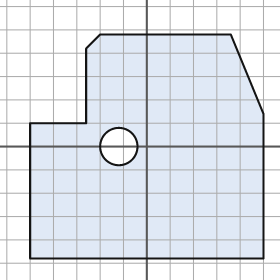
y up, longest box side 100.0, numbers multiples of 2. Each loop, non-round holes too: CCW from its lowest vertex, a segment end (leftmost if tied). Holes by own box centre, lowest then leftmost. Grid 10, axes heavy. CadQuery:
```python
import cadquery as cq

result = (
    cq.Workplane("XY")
    .moveTo(-50.0, -48.0)
    .lineTo(50.0, -48.0)
    .lineTo(50.0, 14.0)
    .lineTo(36.0, 48.0)
    .lineTo(-20.0, 48.0)
    .lineTo(-26.0, 42.0)
    .lineTo(-26.0, 10.0)
    .lineTo(-50.0, 10.0)
    .close()
    .moveTo(-12.0, 0.0)
    .circle(8.0)
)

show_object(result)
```